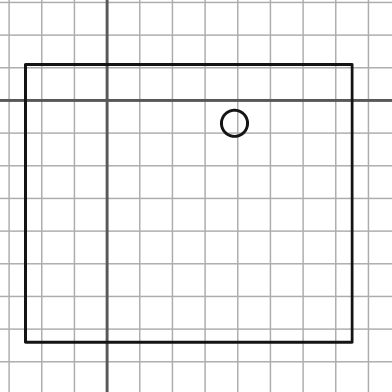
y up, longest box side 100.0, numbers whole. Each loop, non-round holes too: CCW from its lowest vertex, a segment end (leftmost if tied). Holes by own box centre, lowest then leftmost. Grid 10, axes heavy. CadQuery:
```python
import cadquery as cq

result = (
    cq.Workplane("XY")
    .moveTo(-25.0, -74.0)
    .lineTo(75.0, -74.0)
    .lineTo(75.0, 11.0)
    .lineTo(-25.0, 11.0)
    .close()
    .moveTo(39.0, -7.0)
    .circle(4.0)
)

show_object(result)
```